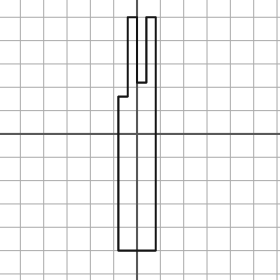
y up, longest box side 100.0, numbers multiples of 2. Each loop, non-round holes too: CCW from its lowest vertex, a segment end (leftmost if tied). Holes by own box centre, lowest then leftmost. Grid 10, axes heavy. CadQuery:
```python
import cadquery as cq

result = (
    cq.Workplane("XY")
    .moveTo(-8.0, -50.0)
    .lineTo(8.0, -50.0)
    .lineTo(8.0, 50.0)
    .lineTo(4.0, 50.0)
    .lineTo(4.0, 22.0)
    .lineTo(0.0, 22.0)
    .lineTo(0.0, 50.0)
    .lineTo(-4.0, 50.0)
    .lineTo(-4.0, 16.0)
    .lineTo(-8.0, 16.0)
    .close()
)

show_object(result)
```